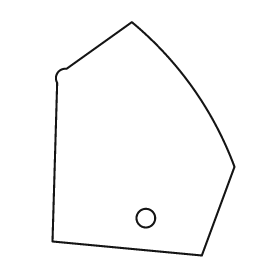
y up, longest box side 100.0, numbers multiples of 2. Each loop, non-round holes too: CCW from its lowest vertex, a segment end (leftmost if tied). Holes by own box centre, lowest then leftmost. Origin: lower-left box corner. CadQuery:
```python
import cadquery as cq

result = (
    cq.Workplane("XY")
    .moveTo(64.0, 0.0)
    .lineTo(78.0, 38.0)
    .threePointArc((60.0, 72.0), (34.0, 100.0))
    .lineTo(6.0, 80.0)
    .threePointArc((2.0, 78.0), (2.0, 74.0))
    .lineTo(0.0, 6.0)
    .close()
    .moveTo(40.0, 16.0)
    .circle(4.0)
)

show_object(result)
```